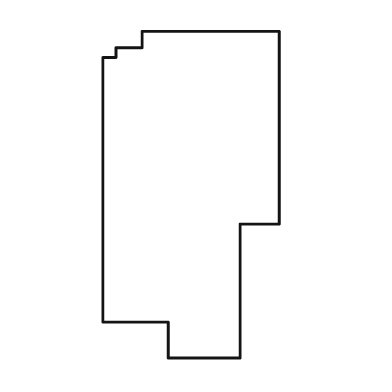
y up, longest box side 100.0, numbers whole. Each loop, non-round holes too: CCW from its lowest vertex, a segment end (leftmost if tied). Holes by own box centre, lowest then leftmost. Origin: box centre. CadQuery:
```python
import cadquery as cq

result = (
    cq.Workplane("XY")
    .moveTo(-7.0, -50.0)
    .lineTo(15.0, -50.0)
    .lineTo(15.0, -9.0)
    .lineTo(27.0, -9.0)
    .lineTo(27.0, 50.0)
    .lineTo(-15.0, 50.0)
    .lineTo(-15.0, 45.0)
    .lineTo(-23.0, 45.0)
    .lineTo(-23.0, 42.0)
    .lineTo(-27.0, 42.0)
    .lineTo(-27.0, -39.0)
    .lineTo(-7.0, -39.0)
    .close()
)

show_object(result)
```